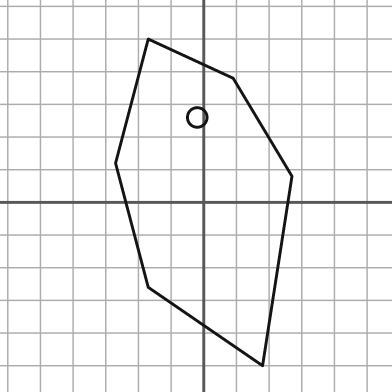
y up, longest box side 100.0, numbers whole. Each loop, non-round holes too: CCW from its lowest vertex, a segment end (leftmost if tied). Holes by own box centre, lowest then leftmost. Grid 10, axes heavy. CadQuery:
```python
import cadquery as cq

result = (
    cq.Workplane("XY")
    .moveTo(18.0, -50.0)
    .lineTo(27.0, 8.0)
    .lineTo(9.0, 38.0)
    .lineTo(-17.0, 50.0)
    .lineTo(-27.0, 12.0)
    .lineTo(-17.0, -26.0)
    .close()
    .moveTo(-2.0, 26.0)
    .circle(3.0)
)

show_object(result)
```